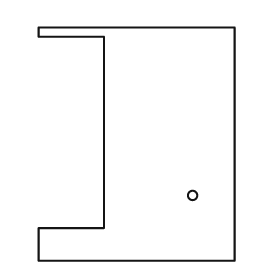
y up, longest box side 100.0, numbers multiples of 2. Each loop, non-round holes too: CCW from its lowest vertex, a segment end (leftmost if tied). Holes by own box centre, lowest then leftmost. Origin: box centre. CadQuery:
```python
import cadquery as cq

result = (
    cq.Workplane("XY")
    .moveTo(-42.0, -50.0)
    .lineTo(42.0, -50.0)
    .lineTo(42.0, 50.0)
    .lineTo(-42.0, 50.0)
    .lineTo(-42.0, 46.0)
    .lineTo(-14.0, 46.0)
    .lineTo(-14.0, -36.0)
    .lineTo(-42.0, -36.0)
    .close()
    .moveTo(24.0, -22.0)
    .circle(2.0)
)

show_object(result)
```